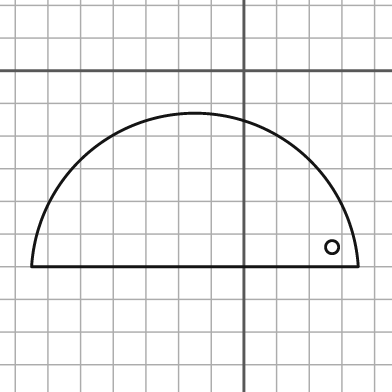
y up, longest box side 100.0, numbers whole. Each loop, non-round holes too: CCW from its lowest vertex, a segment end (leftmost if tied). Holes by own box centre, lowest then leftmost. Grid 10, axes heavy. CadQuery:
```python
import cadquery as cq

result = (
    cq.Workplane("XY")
    .moveTo(-65.0, -60.0)
    .lineTo(35.0, -60.0)
    .threePointArc((-15.0, -13.0), (-65.0, -60.0))
    .close()
    .moveTo(27.0, -54.0)
    .circle(2.0)
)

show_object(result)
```